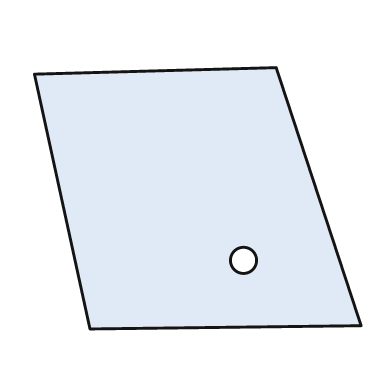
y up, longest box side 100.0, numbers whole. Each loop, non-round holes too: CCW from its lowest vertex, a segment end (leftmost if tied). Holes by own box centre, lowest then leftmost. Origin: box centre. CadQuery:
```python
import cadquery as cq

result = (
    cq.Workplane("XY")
    .moveTo(-33.0, -40.0)
    .lineTo(50.0, -39.0)
    .lineTo(24.0, 40.0)
    .lineTo(-50.0, 38.0)
    .close()
    .moveTo(14.0, -19.0)
    .circle(4.0)
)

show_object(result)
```